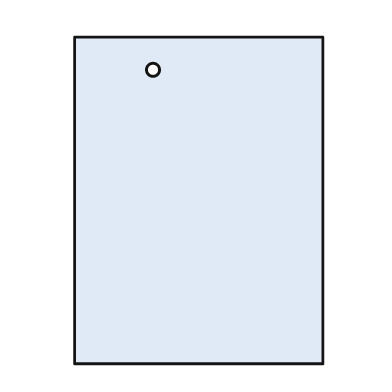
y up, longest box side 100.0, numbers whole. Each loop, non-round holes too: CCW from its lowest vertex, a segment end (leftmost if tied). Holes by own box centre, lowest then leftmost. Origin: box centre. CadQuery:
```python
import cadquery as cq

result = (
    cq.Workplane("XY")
    .moveTo(-38.0, -50.0)
    .lineTo(38.0, -50.0)
    .lineTo(38.0, 50.0)
    .lineTo(-38.0, 50.0)
    .close()
    .moveTo(-14.0, 40.0)
    .circle(2.0)
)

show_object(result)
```